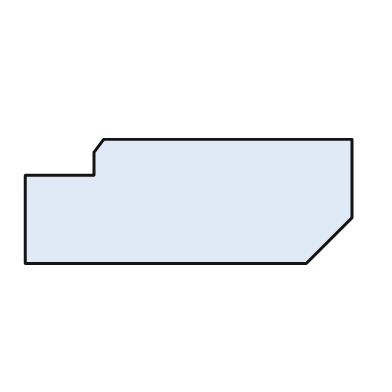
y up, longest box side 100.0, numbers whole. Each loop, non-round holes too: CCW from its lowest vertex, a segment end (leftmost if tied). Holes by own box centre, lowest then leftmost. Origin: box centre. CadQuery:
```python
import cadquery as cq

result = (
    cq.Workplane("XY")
    .moveTo(-50.0, -19.0)
    .lineTo(36.0, -19.0)
    .lineTo(50.0, -5.0)
    .lineTo(50.0, 19.0)
    .lineTo(-26.0, 19.0)
    .lineTo(-29.0, 15.0)
    .lineTo(-29.0, 8.0)
    .lineTo(-50.0, 8.0)
    .close()
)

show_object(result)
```